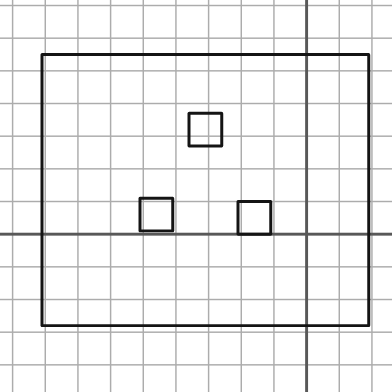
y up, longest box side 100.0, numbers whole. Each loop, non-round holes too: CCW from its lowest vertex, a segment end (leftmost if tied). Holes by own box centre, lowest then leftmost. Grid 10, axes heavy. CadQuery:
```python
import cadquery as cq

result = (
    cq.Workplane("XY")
    .moveTo(-81.0, -28.0)
    .lineTo(19.0, -28.0)
    .lineTo(19.0, 55.0)
    .lineTo(-81.0, 55.0)
    .close()
    .moveTo(-21.0, 0.0)
    .lineTo(-11.0, 0.0)
    .lineTo(-11.0, 10.0)
    .lineTo(-21.0, 10.0)
    .close()
    .moveTo(-51.0, 1.0)
    .lineTo(-41.0, 1.0)
    .lineTo(-41.0, 11.0)
    .lineTo(-51.0, 11.0)
    .close()
    .moveTo(-36.0, 27.0)
    .lineTo(-26.0, 27.0)
    .lineTo(-26.0, 37.0)
    .lineTo(-36.0, 37.0)
    .close()
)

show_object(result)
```